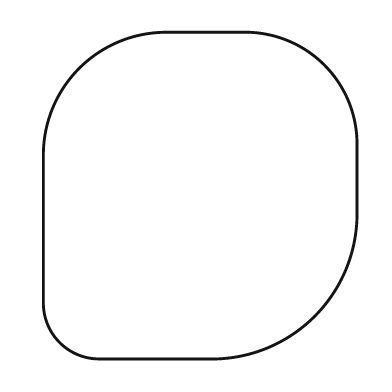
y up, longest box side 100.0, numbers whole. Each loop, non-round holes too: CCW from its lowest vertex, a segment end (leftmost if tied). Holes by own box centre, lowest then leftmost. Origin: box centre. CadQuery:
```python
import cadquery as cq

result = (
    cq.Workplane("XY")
    .moveTo(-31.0, -50.0)
    .lineTo(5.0, -50.0)
    .threePointArc((35.0, -37.0), (48.0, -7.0))
    .lineTo(48.0, 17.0)
    .threePointArc((38.0, 40.0), (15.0, 50.0))
    .lineTo(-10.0, 50.0)
    .threePointArc((-37.0, 39.0), (-48.0, 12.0))
    .lineTo(-48.0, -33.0)
    .threePointArc((-43.0, -45.0), (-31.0, -50.0))
    .close()
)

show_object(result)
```